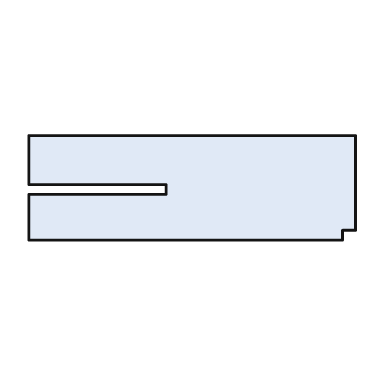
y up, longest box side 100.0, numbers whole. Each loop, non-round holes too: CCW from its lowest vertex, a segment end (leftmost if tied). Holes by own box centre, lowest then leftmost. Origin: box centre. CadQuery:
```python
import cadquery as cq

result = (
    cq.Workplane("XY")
    .moveTo(-50.0, -16.0)
    .lineTo(46.0, -16.0)
    .lineTo(46.0, -13.0)
    .lineTo(50.0, -13.0)
    .lineTo(50.0, 16.0)
    .lineTo(-50.0, 16.0)
    .lineTo(-50.0, 1.0)
    .lineTo(-8.0, 1.0)
    .lineTo(-8.0, -2.0)
    .lineTo(-50.0, -2.0)
    .close()
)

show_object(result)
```